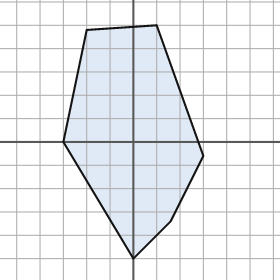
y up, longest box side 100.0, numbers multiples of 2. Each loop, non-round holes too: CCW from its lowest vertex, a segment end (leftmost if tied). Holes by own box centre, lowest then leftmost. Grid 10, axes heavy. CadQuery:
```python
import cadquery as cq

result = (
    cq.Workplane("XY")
    .moveTo(0.0, -50.0)
    .lineTo(16.0, -34.0)
    .lineTo(30.0, -6.0)
    .lineTo(10.0, 50.0)
    .lineTo(-20.0, 48.0)
    .lineTo(-30.0, 0.0)
    .close()
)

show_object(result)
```